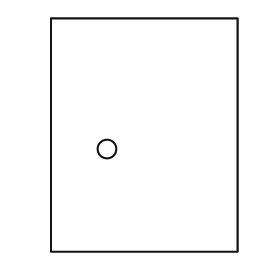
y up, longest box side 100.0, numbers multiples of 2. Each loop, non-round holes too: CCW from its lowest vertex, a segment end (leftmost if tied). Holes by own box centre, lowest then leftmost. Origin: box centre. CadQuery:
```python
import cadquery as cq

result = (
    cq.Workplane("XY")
    .moveTo(-40.0, -50.0)
    .lineTo(40.0, -50.0)
    .lineTo(40.0, 50.0)
    .lineTo(-40.0, 50.0)
    .close()
    .moveTo(-16.0, -6.0)
    .circle(4.0)
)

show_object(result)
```